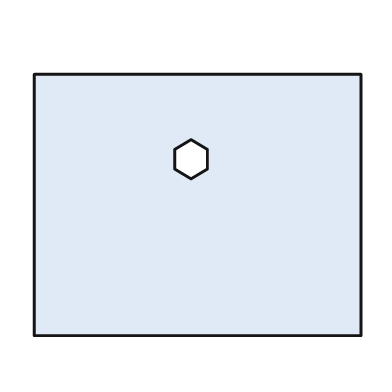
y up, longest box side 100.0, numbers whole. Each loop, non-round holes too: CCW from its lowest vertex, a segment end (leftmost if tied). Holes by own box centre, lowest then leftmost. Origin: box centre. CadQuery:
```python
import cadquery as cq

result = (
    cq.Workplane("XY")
    .moveTo(-50.0, -40.0)
    .lineTo(50.0, -40.0)
    .lineTo(50.0, 40.0)
    .lineTo(-50.0, 40.0)
    .close()
    .moveTo(-2.0, 8.0)
    .lineTo(3.0, 11.0)
    .lineTo(3.0, 17.0)
    .lineTo(-2.0, 20.0)
    .lineTo(-7.0, 17.0)
    .lineTo(-7.0, 11.0)
    .close()
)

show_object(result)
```